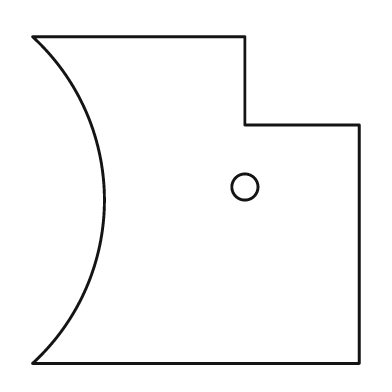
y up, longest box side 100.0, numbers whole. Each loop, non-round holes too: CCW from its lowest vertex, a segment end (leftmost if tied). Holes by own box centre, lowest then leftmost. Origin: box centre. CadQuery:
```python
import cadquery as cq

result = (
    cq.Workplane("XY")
    .moveTo(-50.0, -50.0)
    .lineTo(50.0, -50.0)
    .lineTo(50.0, 23.0)
    .lineTo(15.0, 23.0)
    .lineTo(15.0, 50.0)
    .lineTo(-50.0, 50.0)
    .threePointArc((-28.0, 0.0), (-50.0, -50.0))
    .close()
    .moveTo(15.0, 4.0)
    .circle(4.0)
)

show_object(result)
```